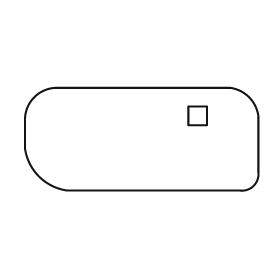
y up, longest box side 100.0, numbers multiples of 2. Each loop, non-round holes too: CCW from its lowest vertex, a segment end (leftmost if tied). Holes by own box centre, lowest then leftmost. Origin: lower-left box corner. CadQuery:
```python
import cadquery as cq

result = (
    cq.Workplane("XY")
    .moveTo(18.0, 0.0)
    .lineTo(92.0, 0.0)
    .threePointArc((98.0, 2.0), (100.0, 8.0))
    .lineTo(100.0, 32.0)
    .threePointArc((96.0, 40.0), (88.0, 44.0))
    .lineTo(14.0, 44.0)
    .threePointArc((4.0, 40.0), (0.0, 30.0))
    .lineTo(0.0, 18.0)
    .threePointArc((6.0, 6.0), (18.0, 0.0))
    .close()
    .moveTo(70.0, 28.0)
    .lineTo(78.0, 28.0)
    .lineTo(78.0, 36.0)
    .lineTo(70.0, 36.0)
    .close()
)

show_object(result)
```